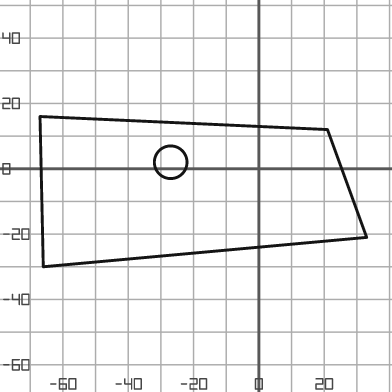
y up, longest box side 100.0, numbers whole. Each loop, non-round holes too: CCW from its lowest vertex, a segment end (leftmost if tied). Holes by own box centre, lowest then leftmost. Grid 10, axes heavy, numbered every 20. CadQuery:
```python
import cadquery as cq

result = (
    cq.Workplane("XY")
    .moveTo(-66.0, -30.0)
    .lineTo(33.0, -21.0)
    .lineTo(21.0, 12.0)
    .lineTo(-67.0, 16.0)
    .close()
    .moveTo(-27.0, 2.0)
    .circle(5.0)
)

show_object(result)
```